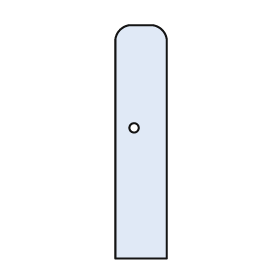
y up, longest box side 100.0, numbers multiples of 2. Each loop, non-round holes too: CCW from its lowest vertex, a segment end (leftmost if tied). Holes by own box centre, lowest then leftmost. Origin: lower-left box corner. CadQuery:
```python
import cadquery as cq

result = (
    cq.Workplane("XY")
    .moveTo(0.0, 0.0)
    .lineTo(22.0, 0.0)
    .lineTo(22.0, 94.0)
    .threePointArc((20.0, 98.0), (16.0, 100.0))
    .lineTo(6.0, 100.0)
    .threePointArc((2.0, 98.0), (0.0, 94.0))
    .close()
    .moveTo(8.0, 56.0)
    .circle(2.0)
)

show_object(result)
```